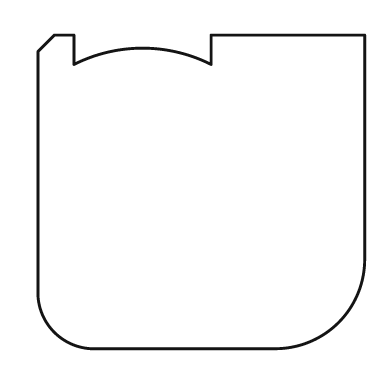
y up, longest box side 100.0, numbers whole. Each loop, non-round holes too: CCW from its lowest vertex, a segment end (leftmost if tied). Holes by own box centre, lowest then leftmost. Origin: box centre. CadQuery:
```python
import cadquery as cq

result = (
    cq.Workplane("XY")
    .moveTo(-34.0, -48.0)
    .lineTo(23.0, -48.0)
    .threePointArc((42.0, -40.0), (50.0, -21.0))
    .lineTo(50.0, 48.0)
    .lineTo(3.0, 48.0)
    .lineTo(3.0, 39.0)
    .threePointArc((-18.0, 44.0), (-39.0, 39.0))
    .lineTo(-39.0, 48.0)
    .lineTo(-45.0, 48.0)
    .lineTo(-50.0, 43.0)
    .lineTo(-50.0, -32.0)
    .threePointArc((-45.0, -43.0), (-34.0, -48.0))
    .close()
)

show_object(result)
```